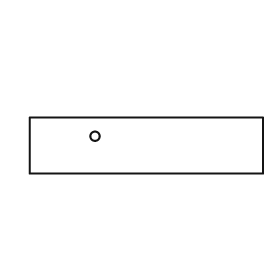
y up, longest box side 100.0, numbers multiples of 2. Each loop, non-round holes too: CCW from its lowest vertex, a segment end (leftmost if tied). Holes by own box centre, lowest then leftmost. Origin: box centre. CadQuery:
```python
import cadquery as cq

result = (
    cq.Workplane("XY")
    .moveTo(-50.0, -12.0)
    .lineTo(50.0, -12.0)
    .lineTo(50.0, 12.0)
    .lineTo(-50.0, 12.0)
    .close()
    .moveTo(-22.0, 4.0)
    .circle(2.0)
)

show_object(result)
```